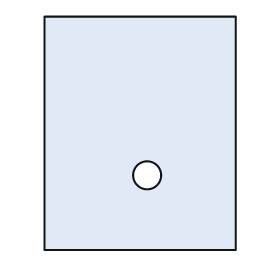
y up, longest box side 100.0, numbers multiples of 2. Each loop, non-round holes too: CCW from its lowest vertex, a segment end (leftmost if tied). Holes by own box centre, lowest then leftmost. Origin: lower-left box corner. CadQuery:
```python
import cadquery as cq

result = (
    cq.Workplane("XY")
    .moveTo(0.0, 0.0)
    .lineTo(82.0, 0.0)
    .lineTo(82.0, 100.0)
    .lineTo(0.0, 100.0)
    .close()
    .moveTo(44.0, 32.0)
    .circle(6.0)
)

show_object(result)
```